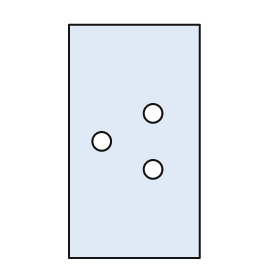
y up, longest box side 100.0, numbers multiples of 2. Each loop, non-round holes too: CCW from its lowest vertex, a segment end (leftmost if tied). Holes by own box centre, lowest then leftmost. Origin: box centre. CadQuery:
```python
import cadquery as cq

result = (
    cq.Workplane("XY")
    .moveTo(-28.0, -50.0)
    .lineTo(28.0, -50.0)
    .lineTo(28.0, 50.0)
    .lineTo(-28.0, 50.0)
    .close()
    .moveTo(8.0, -12.0)
    .circle(4.0)
    .moveTo(-14.0, 0.0)
    .circle(4.0)
    .moveTo(8.0, 12.0)
    .circle(4.0)
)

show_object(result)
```